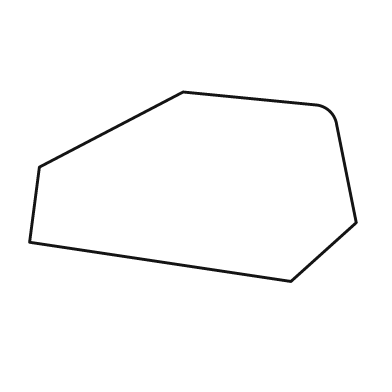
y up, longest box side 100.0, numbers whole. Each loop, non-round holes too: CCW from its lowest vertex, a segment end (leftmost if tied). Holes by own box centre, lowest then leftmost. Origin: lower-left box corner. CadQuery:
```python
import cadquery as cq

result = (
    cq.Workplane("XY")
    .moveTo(80.0, 0.0)
    .lineTo(100.0, 18.0)
    .lineTo(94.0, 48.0)
    .threePointArc((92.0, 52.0), (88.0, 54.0))
    .lineTo(47.0, 58.0)
    .lineTo(3.0, 35.0)
    .lineTo(0.0, 12.0)
    .close()
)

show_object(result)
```